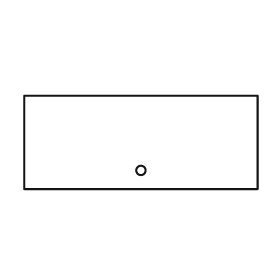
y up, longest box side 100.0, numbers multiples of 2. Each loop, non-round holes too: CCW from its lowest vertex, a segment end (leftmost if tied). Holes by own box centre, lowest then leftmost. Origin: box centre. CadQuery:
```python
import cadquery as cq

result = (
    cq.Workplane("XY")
    .moveTo(-50.0, -20.0)
    .lineTo(50.0, -20.0)
    .lineTo(50.0, 20.0)
    .lineTo(-50.0, 20.0)
    .close()
    .moveTo(0.0, -12.0)
    .circle(2.0)
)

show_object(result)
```